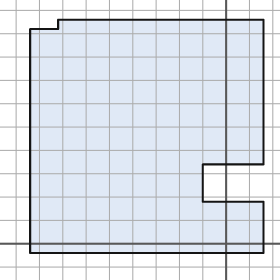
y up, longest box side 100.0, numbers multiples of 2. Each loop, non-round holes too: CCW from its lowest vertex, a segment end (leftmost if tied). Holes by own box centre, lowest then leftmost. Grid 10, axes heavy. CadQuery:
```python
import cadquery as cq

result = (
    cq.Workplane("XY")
    .moveTo(-84.0, -4.0)
    .lineTo(16.0, -4.0)
    .lineTo(16.0, 18.0)
    .lineTo(-10.0, 18.0)
    .lineTo(-10.0, 34.0)
    .lineTo(16.0, 34.0)
    .lineTo(16.0, 96.0)
    .lineTo(-72.0, 96.0)
    .lineTo(-72.0, 92.0)
    .lineTo(-84.0, 92.0)
    .close()
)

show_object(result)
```